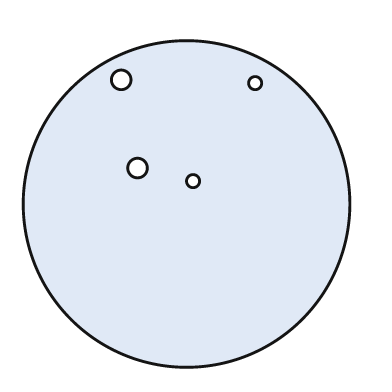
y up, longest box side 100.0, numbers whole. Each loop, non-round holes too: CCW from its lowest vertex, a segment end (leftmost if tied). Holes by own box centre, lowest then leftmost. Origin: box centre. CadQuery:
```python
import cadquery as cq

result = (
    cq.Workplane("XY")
    .moveTo(0.0, 0.0)
    .circle(50.0)
    .moveTo(2.0, 7.0)
    .circle(2.0)
    .moveTo(-15.0, 11.0)
    .circle(3.0)
    .moveTo(21.0, 37.0)
    .circle(2.0)
    .moveTo(-20.0, 38.0)
    .circle(3.0)
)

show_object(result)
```